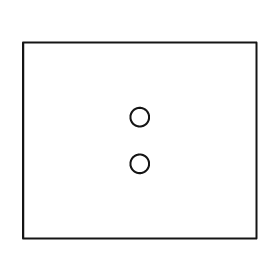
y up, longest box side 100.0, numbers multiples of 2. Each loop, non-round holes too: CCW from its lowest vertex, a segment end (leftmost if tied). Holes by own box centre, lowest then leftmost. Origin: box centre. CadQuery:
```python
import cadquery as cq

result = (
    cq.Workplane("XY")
    .moveTo(-50.0, -42.0)
    .lineTo(50.0, -42.0)
    .lineTo(50.0, 42.0)
    .lineTo(-50.0, 42.0)
    .close()
    .moveTo(0.0, -10.0)
    .circle(4.0)
    .moveTo(0.0, 10.0)
    .circle(4.0)
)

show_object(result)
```